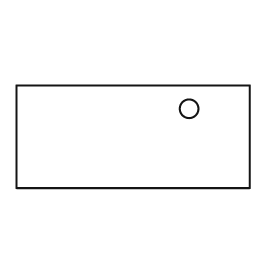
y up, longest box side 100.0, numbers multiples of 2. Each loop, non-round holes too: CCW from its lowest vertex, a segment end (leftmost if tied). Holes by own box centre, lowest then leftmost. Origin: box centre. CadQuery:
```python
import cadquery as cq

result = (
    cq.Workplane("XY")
    .moveTo(-50.0, -22.0)
    .lineTo(50.0, -22.0)
    .lineTo(50.0, 22.0)
    .lineTo(-50.0, 22.0)
    .close()
    .moveTo(24.0, 12.0)
    .circle(4.0)
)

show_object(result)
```